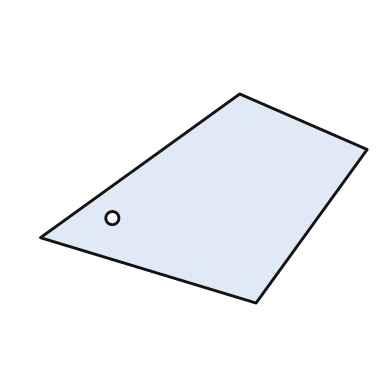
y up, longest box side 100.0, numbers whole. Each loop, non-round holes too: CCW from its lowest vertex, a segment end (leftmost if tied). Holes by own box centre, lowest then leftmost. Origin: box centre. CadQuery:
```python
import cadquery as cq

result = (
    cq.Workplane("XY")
    .moveTo(16.0, -32.0)
    .lineTo(50.0, 15.0)
    .lineTo(11.0, 32.0)
    .lineTo(-50.0, -12.0)
    .close()
    .moveTo(-28.0, -6.0)
    .circle(2.0)
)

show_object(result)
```